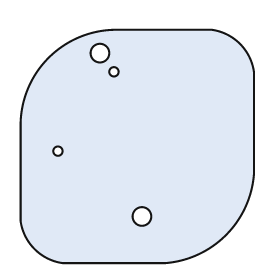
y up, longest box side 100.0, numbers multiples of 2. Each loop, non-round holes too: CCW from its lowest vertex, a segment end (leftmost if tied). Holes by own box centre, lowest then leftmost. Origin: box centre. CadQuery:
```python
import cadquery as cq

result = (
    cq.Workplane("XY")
    .moveTo(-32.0, -50.0)
    .lineTo(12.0, -50.0)
    .threePointArc((38.0, -38.0), (50.0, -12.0))
    .lineTo(50.0, 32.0)
    .threePointArc((44.0, 44.0), (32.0, 50.0))
    .lineTo(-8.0, 50.0)
    .threePointArc((-38.0, 38.0), (-50.0, 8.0))
    .lineTo(-50.0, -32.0)
    .threePointArc((-44.0, -44.0), (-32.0, -50.0))
    .close()
    .moveTo(2.0, -30.0)
    .circle(4.0)
    .moveTo(-34.0, -2.0)
    .circle(2.0)
    .moveTo(-10.0, 32.0)
    .circle(2.0)
    .moveTo(-16.0, 40.0)
    .circle(4.0)
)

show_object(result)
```